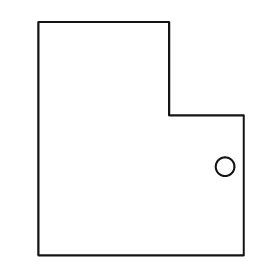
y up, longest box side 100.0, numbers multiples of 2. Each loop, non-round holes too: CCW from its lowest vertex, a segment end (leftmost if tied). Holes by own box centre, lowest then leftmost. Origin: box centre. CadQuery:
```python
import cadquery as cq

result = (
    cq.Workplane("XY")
    .moveTo(-44.0, -50.0)
    .lineTo(44.0, -50.0)
    .lineTo(44.0, 10.0)
    .lineTo(12.0, 10.0)
    .lineTo(12.0, 50.0)
    .lineTo(-44.0, 50.0)
    .close()
    .moveTo(36.0, -12.0)
    .circle(4.0)
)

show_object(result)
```